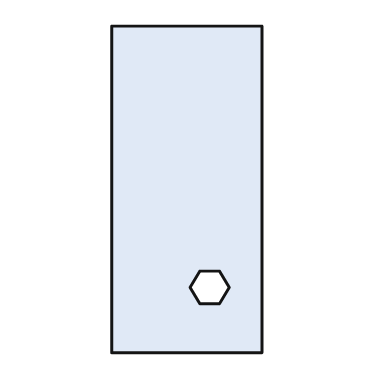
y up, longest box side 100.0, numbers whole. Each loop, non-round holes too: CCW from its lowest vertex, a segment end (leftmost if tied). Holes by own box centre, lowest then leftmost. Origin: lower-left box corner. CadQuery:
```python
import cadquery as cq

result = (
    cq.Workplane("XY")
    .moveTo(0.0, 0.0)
    .lineTo(46.0, 0.0)
    .lineTo(46.0, 100.0)
    .lineTo(0.0, 100.0)
    .close()
    .moveTo(27.0, 15.0)
    .lineTo(33.0, 15.0)
    .lineTo(36.0, 20.0)
    .lineTo(33.0, 25.0)
    .lineTo(27.0, 25.0)
    .lineTo(24.0, 20.0)
    .close()
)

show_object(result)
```